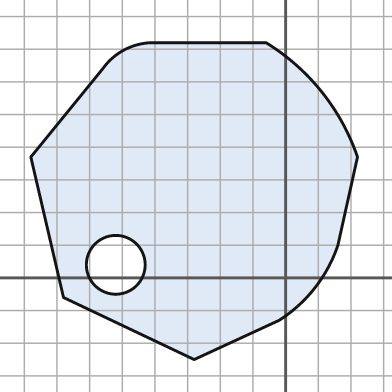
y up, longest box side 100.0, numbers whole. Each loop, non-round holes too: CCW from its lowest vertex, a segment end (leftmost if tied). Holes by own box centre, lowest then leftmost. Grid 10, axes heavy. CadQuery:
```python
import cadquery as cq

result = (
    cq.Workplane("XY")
    .moveTo(-28.0, -25.0)
    .lineTo(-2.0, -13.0)
    .threePointArc((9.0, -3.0), (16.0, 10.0))
    .lineTo(22.0, 37.0)
    .threePointArc((11.0, 57.0), (-6.0, 72.0))
    .lineTo(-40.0, 72.0)
    .threePointArc((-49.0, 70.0), (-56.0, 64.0))
    .lineTo(-78.0, 37.0)
    .lineTo(-68.0, -6.0)
    .close()
    .moveTo(-52.0, 4.0)
    .circle(9.0)
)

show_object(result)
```